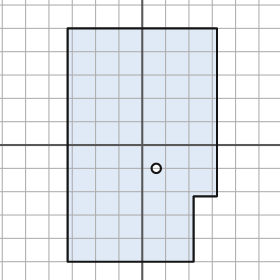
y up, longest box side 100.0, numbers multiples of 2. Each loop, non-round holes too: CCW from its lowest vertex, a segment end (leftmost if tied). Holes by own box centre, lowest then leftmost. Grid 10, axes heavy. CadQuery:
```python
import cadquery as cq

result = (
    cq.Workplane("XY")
    .moveTo(-32.0, -50.0)
    .lineTo(22.0, -50.0)
    .lineTo(22.0, -22.0)
    .lineTo(32.0, -22.0)
    .lineTo(32.0, 50.0)
    .lineTo(-32.0, 50.0)
    .close()
    .moveTo(6.0, -10.0)
    .circle(2.0)
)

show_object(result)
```